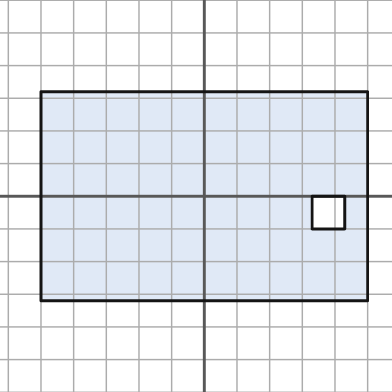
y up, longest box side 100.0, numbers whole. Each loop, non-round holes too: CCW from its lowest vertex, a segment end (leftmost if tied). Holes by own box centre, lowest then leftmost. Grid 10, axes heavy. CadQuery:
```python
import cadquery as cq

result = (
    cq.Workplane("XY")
    .moveTo(-50.0, -32.0)
    .lineTo(50.0, -32.0)
    .lineTo(50.0, 32.0)
    .lineTo(-50.0, 32.0)
    .close()
    .moveTo(33.0, -10.0)
    .lineTo(43.0, -10.0)
    .lineTo(43.0, 0.0)
    .lineTo(33.0, 0.0)
    .close()
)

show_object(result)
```